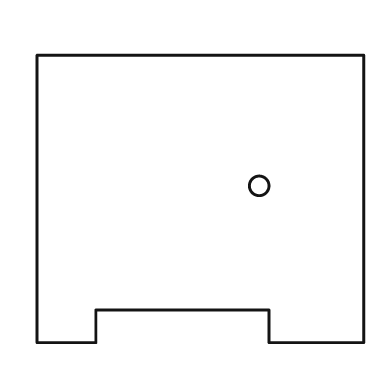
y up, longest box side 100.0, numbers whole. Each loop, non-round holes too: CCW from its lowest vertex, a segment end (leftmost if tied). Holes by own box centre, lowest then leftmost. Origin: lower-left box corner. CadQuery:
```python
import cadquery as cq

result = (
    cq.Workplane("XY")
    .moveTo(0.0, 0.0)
    .lineTo(18.0, 0.0)
    .lineTo(18.0, 10.0)
    .lineTo(71.0, 10.0)
    .lineTo(71.0, 0.0)
    .lineTo(100.0, 0.0)
    .lineTo(100.0, 88.0)
    .lineTo(0.0, 88.0)
    .close()
    .moveTo(68.0, 48.0)
    .circle(3.0)
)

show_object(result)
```